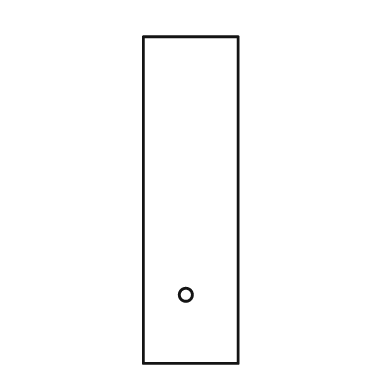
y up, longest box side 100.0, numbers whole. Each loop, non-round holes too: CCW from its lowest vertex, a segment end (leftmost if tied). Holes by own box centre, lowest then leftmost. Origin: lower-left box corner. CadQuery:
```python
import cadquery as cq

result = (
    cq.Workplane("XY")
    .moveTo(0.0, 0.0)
    .lineTo(29.0, 0.0)
    .lineTo(29.0, 100.0)
    .lineTo(0.0, 100.0)
    .close()
    .moveTo(13.0, 21.0)
    .circle(2.0)
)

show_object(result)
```